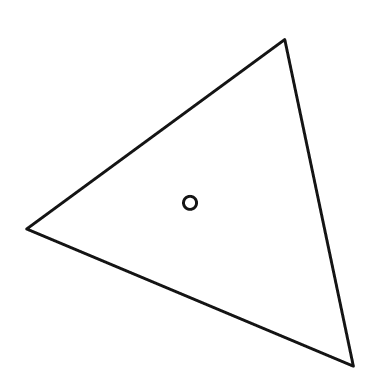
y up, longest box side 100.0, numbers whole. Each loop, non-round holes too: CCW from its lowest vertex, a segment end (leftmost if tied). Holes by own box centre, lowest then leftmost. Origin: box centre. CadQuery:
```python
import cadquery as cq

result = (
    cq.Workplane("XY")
    .moveTo(50.0, -50.0)
    .lineTo(29.0, 50.0)
    .lineTo(-50.0, -8.0)
    .close()
    .moveTo(0.0, 0.0)
    .circle(2.0)
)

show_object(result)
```